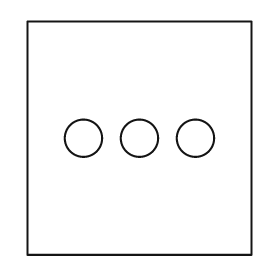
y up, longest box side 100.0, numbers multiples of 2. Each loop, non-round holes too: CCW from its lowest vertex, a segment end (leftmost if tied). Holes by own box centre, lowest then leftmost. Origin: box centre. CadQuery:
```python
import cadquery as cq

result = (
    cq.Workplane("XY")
    .moveTo(-48.0, -50.0)
    .lineTo(48.0, -50.0)
    .lineTo(48.0, 50.0)
    .lineTo(-48.0, 50.0)
    .close()
    .moveTo(-24.0, 0.0)
    .circle(8.0)
    .moveTo(0.0, 0.0)
    .circle(8.0)
    .moveTo(24.0, 0.0)
    .circle(8.0)
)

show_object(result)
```